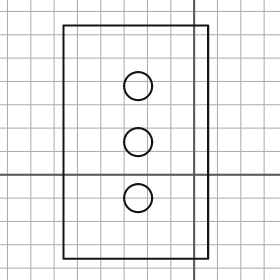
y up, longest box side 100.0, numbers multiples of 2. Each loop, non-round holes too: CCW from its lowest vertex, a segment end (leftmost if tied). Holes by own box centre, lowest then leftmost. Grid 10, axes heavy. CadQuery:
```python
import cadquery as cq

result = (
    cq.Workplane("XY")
    .moveTo(-56.0, -36.0)
    .lineTo(6.0, -36.0)
    .lineTo(6.0, 64.0)
    .lineTo(-56.0, 64.0)
    .close()
    .moveTo(-24.0, -10.0)
    .circle(6.0)
    .moveTo(-24.0, 14.0)
    .circle(6.0)
    .moveTo(-24.0, 38.0)
    .circle(6.0)
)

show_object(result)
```